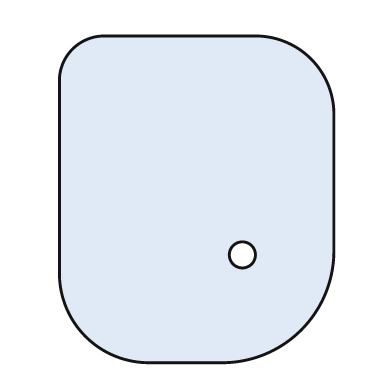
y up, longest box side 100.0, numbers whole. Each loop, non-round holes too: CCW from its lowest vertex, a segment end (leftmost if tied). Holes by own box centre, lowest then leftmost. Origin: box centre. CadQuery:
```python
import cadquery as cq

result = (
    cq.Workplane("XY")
    .moveTo(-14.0, -50.0)
    .lineTo(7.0, -50.0)
    .threePointArc((32.0, -40.0), (42.0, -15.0))
    .lineTo(42.0, 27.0)
    .threePointArc((35.0, 43.0), (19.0, 50.0))
    .lineTo(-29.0, 50.0)
    .threePointArc((-38.0, 46.0), (-42.0, 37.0))
    .lineTo(-42.0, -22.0)
    .threePointArc((-34.0, -42.0), (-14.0, -50.0))
    .close()
    .moveTo(14.0, -17.0)
    .circle(4.0)
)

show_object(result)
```